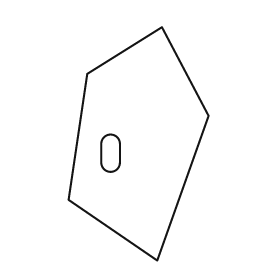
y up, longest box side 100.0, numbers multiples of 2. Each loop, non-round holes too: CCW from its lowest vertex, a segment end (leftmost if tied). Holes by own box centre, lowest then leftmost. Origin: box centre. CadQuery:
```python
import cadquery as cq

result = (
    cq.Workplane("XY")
    .moveTo(8.0, -50.0)
    .lineTo(30.0, 12.0)
    .lineTo(10.0, 50.0)
    .lineTo(-22.0, 30.0)
    .lineTo(-30.0, -24.0)
    .close()
    .moveTo(-16.0, -8.0)
    .threePointArc((-12.0, -12.0), (-8.0, -8.0))
    .lineTo(-8.0, 0.0)
    .threePointArc((-12.0, 4.0), (-16.0, 0.0))
    .close()
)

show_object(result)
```